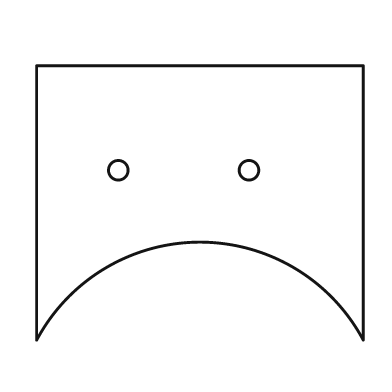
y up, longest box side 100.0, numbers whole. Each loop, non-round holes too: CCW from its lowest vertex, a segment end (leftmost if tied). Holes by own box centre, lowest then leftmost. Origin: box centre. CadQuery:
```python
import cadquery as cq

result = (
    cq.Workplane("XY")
    .moveTo(-50.0, -42.0)
    .threePointArc((0.0, -12.0), (50.0, -42.0))
    .lineTo(50.0, 42.0)
    .lineTo(-50.0, 42.0)
    .close()
    .moveTo(-25.0, 10.0)
    .circle(3.0)
    .moveTo(15.0, 10.0)
    .circle(3.0)
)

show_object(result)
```